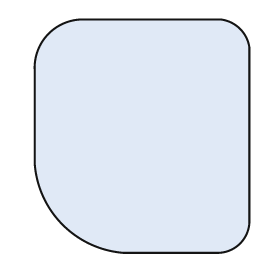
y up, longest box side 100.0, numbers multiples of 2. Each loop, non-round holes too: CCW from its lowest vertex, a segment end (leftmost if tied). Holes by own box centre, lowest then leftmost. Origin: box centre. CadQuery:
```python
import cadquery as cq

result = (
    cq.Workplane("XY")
    .moveTo(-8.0, -50.0)
    .lineTo(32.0, -50.0)
    .threePointArc((42.0, -46.0), (46.0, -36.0))
    .lineTo(46.0, 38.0)
    .threePointArc((42.0, 46.0), (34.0, 50.0))
    .lineTo(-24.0, 50.0)
    .threePointArc((-40.0, 44.0), (-46.0, 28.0))
    .lineTo(-46.0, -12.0)
    .threePointArc((-34.0, -38.0), (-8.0, -50.0))
    .close()
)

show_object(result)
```